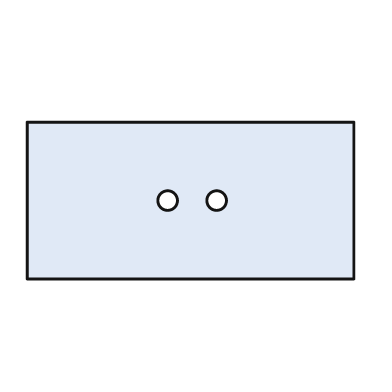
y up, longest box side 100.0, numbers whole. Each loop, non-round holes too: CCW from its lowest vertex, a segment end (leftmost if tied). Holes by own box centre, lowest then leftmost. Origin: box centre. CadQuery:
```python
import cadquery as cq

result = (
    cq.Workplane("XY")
    .moveTo(-50.0, -24.0)
    .lineTo(50.0, -24.0)
    .lineTo(50.0, 24.0)
    .lineTo(-50.0, 24.0)
    .close()
    .moveTo(-7.0, 0.0)
    .circle(3.0)
    .moveTo(8.0, 0.0)
    .circle(3.0)
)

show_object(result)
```